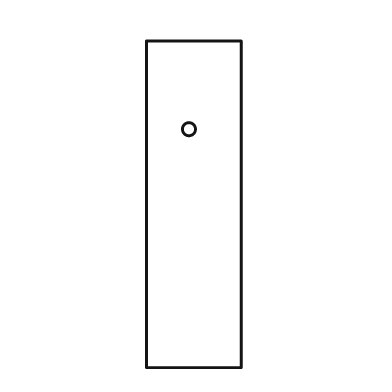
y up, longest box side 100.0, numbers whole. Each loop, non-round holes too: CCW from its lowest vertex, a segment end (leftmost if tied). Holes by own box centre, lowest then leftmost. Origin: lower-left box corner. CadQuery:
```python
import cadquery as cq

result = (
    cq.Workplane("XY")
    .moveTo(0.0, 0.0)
    .lineTo(29.0, 0.0)
    .lineTo(29.0, 100.0)
    .lineTo(0.0, 100.0)
    .close()
    .moveTo(13.0, 73.0)
    .circle(2.0)
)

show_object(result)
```